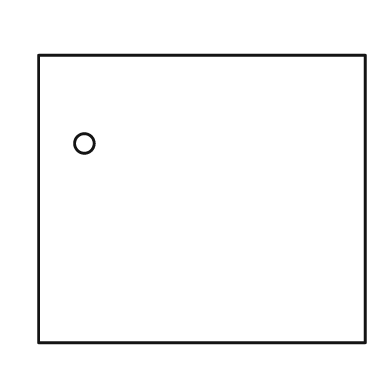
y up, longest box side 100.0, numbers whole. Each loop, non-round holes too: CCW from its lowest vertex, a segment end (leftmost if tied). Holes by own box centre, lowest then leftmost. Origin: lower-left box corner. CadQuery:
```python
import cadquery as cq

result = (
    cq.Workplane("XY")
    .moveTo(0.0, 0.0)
    .lineTo(100.0, 0.0)
    .lineTo(100.0, 88.0)
    .lineTo(0.0, 88.0)
    .close()
    .moveTo(14.0, 61.0)
    .circle(3.0)
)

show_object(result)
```